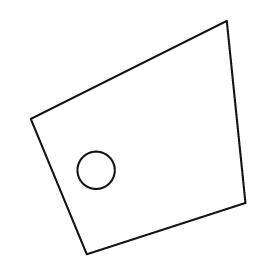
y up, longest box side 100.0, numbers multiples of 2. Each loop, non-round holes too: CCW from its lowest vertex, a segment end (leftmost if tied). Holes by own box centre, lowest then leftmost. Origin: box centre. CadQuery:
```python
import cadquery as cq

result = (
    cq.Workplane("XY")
    .moveTo(-22.0, -50.0)
    .lineTo(46.0, -28.0)
    .lineTo(38.0, 50.0)
    .lineTo(-46.0, 8.0)
    .close()
    .moveTo(-18.0, -14.0)
    .circle(8.0)
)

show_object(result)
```